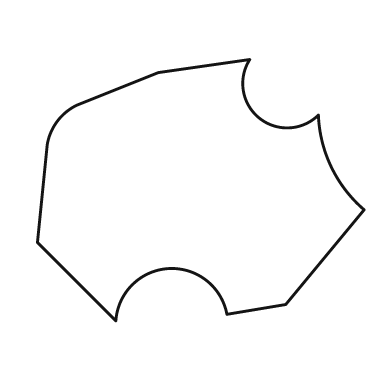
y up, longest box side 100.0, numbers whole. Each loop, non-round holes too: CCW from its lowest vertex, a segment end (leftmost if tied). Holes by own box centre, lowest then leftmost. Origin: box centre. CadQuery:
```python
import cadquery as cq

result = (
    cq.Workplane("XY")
    .moveTo(-26.0, -40.0)
    .threePointArc((-10.0, -24.0), (8.0, -38.0))
    .lineTo(26.0, -35.0)
    .lineTo(50.0, -6.0)
    .threePointArc((40.0, 7.0), (36.0, 23.0))
    .threePointArc((18.0, 22.0), (15.0, 40.0))
    .lineTo(-13.0, 36.0)
    .lineTo(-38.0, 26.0)
    .threePointArc((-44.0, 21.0), (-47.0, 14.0))
    .lineTo(-50.0, -16.0)
    .close()
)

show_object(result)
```